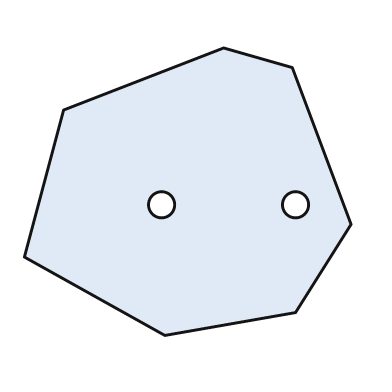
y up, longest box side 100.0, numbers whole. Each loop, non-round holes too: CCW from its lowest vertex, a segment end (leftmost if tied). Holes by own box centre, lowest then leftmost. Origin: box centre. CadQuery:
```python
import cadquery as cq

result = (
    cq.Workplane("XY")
    .moveTo(-7.0, -44.0)
    .lineTo(33.0, -37.0)
    .lineTo(50.0, -10.0)
    .lineTo(32.0, 38.0)
    .lineTo(11.0, 44.0)
    .lineTo(-38.0, 25.0)
    .lineTo(-50.0, -20.0)
    .close()
    .moveTo(-8.0, -4.0)
    .circle(4.0)
    .moveTo(33.0, -4.0)
    .circle(4.0)
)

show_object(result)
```